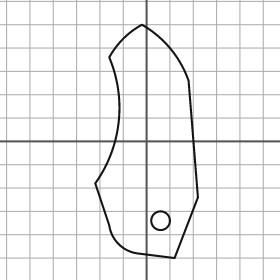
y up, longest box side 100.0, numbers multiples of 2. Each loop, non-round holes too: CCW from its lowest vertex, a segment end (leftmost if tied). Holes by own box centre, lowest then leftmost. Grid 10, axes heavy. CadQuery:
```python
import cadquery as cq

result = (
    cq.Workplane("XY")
    .moveTo(12.0, -50.0)
    .lineTo(22.0, -24.0)
    .lineTo(18.0, 26.0)
    .threePointArc((10.0, 40.0), (-2.0, 50.0))
    .threePointArc((-10.0, 44.0), (-16.0, 36.0))
    .threePointArc((-12.0, 8.0), (-22.0, -18.0))
    .lineTo(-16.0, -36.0)
    .threePointArc((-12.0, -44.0), (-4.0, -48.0))
    .close()
    .moveTo(6.0, -34.0)
    .circle(4.0)
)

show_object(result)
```